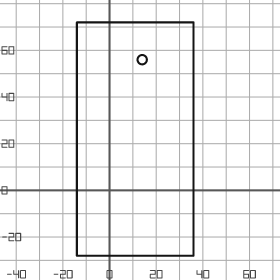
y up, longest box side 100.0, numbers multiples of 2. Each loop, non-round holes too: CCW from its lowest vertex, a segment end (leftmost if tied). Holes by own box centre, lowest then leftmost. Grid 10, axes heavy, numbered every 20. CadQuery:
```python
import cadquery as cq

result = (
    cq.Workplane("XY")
    .moveTo(-14.0, -28.0)
    .lineTo(36.0, -28.0)
    .lineTo(36.0, 72.0)
    .lineTo(-14.0, 72.0)
    .close()
    .moveTo(14.0, 56.0)
    .circle(2.0)
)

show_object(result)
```